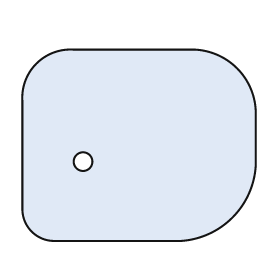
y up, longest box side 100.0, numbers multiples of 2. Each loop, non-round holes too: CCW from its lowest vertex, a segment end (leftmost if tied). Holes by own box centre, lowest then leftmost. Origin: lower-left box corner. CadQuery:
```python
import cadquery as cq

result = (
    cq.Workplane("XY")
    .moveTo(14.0, 0.0)
    .lineTo(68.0, 0.0)
    .threePointArc((90.0, 10.0), (100.0, 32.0))
    .lineTo(100.0, 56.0)
    .threePointArc((92.0, 74.0), (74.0, 82.0))
    .lineTo(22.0, 82.0)
    .threePointArc((6.0, 76.0), (0.0, 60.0))
    .lineTo(0.0, 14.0)
    .threePointArc((4.0, 4.0), (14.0, 0.0))
    .close()
    .moveTo(26.0, 34.0)
    .circle(4.0)
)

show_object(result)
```